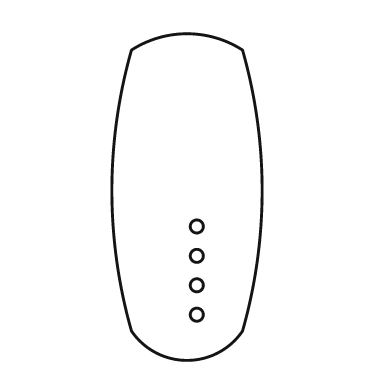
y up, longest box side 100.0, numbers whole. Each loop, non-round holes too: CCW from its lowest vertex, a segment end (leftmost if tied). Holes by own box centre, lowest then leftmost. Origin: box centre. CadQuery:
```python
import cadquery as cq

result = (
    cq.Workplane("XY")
    .moveTo(-17.0, -41.0)
    .threePointArc((0.0, -50.0), (17.0, -41.0))
    .threePointArc((23.0, 2.0), (17.0, 45.0))
    .threePointArc((0.0, 50.0), (-17.0, 45.0))
    .threePointArc((-23.0, 2.0), (-17.0, -41.0))
    .close()
    .moveTo(3.0, -36.0)
    .circle(2.0)
    .moveTo(3.0, -27.0)
    .circle(2.0)
    .moveTo(3.0, -18.0)
    .circle(2.0)
    .moveTo(3.0, -9.0)
    .circle(2.0)
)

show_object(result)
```